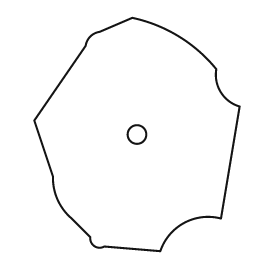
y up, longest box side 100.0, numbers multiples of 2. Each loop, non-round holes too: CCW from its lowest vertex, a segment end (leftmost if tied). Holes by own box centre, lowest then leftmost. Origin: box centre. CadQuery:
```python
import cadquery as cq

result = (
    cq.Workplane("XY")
    .moveTo(10.0, -50.0)
    .threePointArc((20.0, -38.0), (36.0, -36.0))
    .lineTo(44.0, 12.0)
    .threePointArc((36.0, 18.0), (34.0, 28.0))
    .threePointArc((18.0, 42.0), (-2.0, 50.0))
    .lineTo(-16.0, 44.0)
    .threePointArc((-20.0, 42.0), (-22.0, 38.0))
    .lineTo(-44.0, 6.0)
    .lineTo(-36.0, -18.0)
    .threePointArc((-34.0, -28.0), (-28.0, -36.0))
    .lineTo(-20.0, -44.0)
    .threePointArc((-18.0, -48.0), (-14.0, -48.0))
    .close()
    .moveTo(0.0, 0.0)
    .circle(4.0)
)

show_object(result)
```